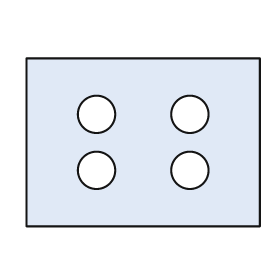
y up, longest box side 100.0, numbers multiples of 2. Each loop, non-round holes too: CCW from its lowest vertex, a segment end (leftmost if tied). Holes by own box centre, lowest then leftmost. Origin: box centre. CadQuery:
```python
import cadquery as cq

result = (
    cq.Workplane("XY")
    .moveTo(-50.0, -36.0)
    .lineTo(50.0, -36.0)
    .lineTo(50.0, 36.0)
    .lineTo(-50.0, 36.0)
    .close()
    .moveTo(-20.0, -12.0)
    .circle(8.0)
    .moveTo(20.0, -12.0)
    .circle(8.0)
    .moveTo(-20.0, 12.0)
    .circle(8.0)
    .moveTo(20.0, 12.0)
    .circle(8.0)
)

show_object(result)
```